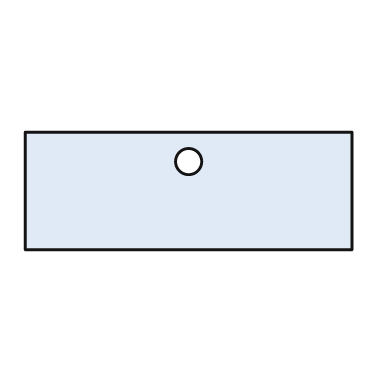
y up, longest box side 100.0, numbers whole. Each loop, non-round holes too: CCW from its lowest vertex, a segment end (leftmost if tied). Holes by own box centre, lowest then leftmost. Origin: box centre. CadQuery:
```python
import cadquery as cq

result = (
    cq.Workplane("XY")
    .moveTo(-50.0, -18.0)
    .lineTo(50.0, -18.0)
    .lineTo(50.0, 18.0)
    .lineTo(-50.0, 18.0)
    .close()
    .moveTo(0.0, 9.0)
    .circle(4.0)
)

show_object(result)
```